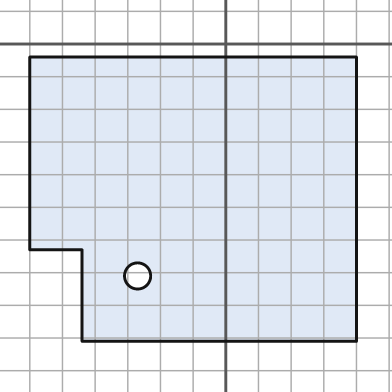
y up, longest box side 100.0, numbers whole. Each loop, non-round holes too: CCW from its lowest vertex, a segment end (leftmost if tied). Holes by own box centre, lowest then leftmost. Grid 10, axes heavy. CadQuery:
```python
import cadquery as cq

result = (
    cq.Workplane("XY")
    .moveTo(-44.0, -91.0)
    .lineTo(40.0, -91.0)
    .lineTo(40.0, -4.0)
    .lineTo(-60.0, -4.0)
    .lineTo(-60.0, -63.0)
    .lineTo(-44.0, -63.0)
    .close()
    .moveTo(-27.0, -71.0)
    .circle(4.0)
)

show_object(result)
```